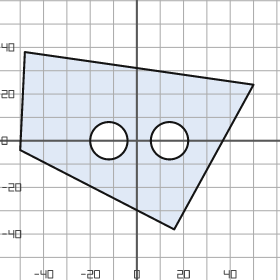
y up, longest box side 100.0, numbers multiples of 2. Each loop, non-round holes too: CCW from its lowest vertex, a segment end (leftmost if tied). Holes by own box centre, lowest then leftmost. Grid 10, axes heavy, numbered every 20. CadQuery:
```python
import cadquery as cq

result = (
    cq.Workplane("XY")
    .moveTo(16.0, -38.0)
    .lineTo(50.0, 24.0)
    .lineTo(-48.0, 38.0)
    .lineTo(-50.0, -4.0)
    .close()
    .moveTo(-12.0, 0.0)
    .circle(8.0)
    .moveTo(14.0, 0.0)
    .circle(8.0)
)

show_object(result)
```